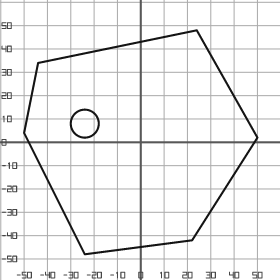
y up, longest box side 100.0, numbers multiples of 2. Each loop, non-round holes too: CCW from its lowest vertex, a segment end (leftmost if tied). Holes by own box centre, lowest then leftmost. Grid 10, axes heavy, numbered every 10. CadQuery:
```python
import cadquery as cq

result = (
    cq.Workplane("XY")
    .moveTo(-24.0, -48.0)
    .lineTo(22.0, -42.0)
    .lineTo(50.0, 2.0)
    .lineTo(24.0, 48.0)
    .lineTo(-44.0, 34.0)
    .lineTo(-50.0, 4.0)
    .close()
    .moveTo(-24.0, 8.0)
    .circle(6.0)
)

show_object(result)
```